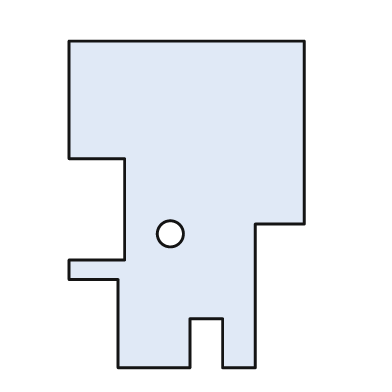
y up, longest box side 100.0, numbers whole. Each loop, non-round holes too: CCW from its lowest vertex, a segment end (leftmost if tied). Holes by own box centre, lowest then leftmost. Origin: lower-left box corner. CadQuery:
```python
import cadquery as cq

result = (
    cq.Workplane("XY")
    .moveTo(15.0, 0.0)
    .lineTo(37.0, 0.0)
    .lineTo(37.0, 15.0)
    .lineTo(47.0, 15.0)
    .lineTo(47.0, 0.0)
    .lineTo(57.0, 0.0)
    .lineTo(57.0, 44.0)
    .lineTo(72.0, 44.0)
    .lineTo(72.0, 100.0)
    .lineTo(0.0, 100.0)
    .lineTo(0.0, 64.0)
    .lineTo(17.0, 64.0)
    .lineTo(17.0, 33.0)
    .lineTo(0.0, 33.0)
    .lineTo(0.0, 27.0)
    .lineTo(15.0, 27.0)
    .close()
    .moveTo(31.0, 41.0)
    .circle(4.0)
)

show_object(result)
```